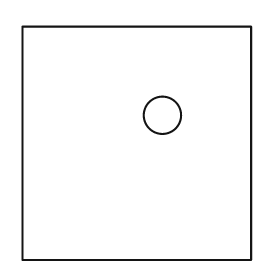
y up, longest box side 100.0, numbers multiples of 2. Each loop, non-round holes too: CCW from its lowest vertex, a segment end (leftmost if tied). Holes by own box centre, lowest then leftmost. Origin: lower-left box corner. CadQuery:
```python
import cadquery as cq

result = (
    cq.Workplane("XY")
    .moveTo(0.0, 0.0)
    .lineTo(98.0, 0.0)
    .lineTo(98.0, 100.0)
    .lineTo(0.0, 100.0)
    .close()
    .moveTo(60.0, 62.0)
    .circle(8.0)
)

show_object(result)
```